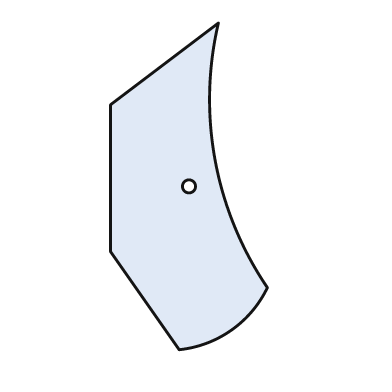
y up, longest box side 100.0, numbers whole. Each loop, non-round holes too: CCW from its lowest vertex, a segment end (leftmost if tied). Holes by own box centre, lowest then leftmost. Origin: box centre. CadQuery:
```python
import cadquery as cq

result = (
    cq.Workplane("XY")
    .moveTo(-3.0, -50.0)
    .threePointArc((13.0, -44.0), (24.0, -31.0))
    .threePointArc((8.0, 8.0), (9.0, 50.0))
    .lineTo(-24.0, 25.0)
    .lineTo(-24.0, -20.0)
    .close()
    .moveTo(0.0, 0.0)
    .circle(2.0)
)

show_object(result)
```